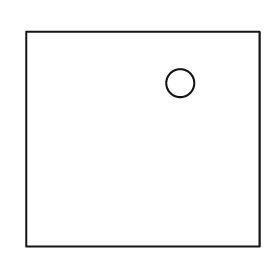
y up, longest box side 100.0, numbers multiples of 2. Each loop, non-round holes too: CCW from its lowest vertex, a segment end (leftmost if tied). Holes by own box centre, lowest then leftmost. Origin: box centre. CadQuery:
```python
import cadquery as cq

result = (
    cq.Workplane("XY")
    .moveTo(-50.0, -46.0)
    .lineTo(50.0, -46.0)
    .lineTo(50.0, 46.0)
    .lineTo(-50.0, 46.0)
    .close()
    .moveTo(16.0, 24.0)
    .circle(6.0)
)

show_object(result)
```